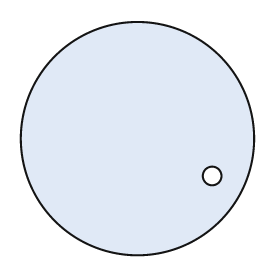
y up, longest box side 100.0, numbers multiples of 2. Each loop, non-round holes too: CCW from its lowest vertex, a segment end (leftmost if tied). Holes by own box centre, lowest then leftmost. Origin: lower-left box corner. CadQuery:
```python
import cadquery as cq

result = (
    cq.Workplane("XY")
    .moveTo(50.0, 50.0)
    .circle(50.0)
    .moveTo(82.0, 34.0)
    .circle(4.0)
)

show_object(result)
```